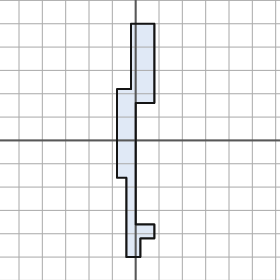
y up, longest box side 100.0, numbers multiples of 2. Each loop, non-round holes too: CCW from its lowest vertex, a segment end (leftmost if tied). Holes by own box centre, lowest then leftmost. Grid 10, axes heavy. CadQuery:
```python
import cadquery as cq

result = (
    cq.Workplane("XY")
    .moveTo(-4.0, -50.0)
    .lineTo(2.0, -50.0)
    .lineTo(2.0, -42.0)
    .lineTo(8.0, -42.0)
    .lineTo(8.0, -36.0)
    .lineTo(0.0, -36.0)
    .lineTo(0.0, 16.0)
    .lineTo(8.0, 16.0)
    .lineTo(8.0, 50.0)
    .lineTo(-2.0, 50.0)
    .lineTo(-2.0, 22.0)
    .lineTo(-8.0, 22.0)
    .lineTo(-8.0, -16.0)
    .lineTo(-4.0, -16.0)
    .close()
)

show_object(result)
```